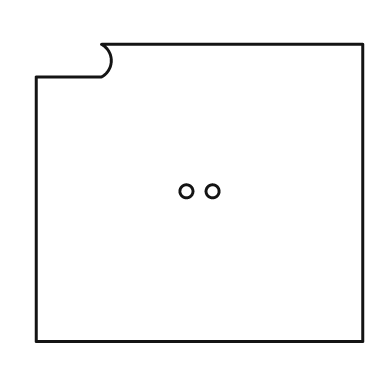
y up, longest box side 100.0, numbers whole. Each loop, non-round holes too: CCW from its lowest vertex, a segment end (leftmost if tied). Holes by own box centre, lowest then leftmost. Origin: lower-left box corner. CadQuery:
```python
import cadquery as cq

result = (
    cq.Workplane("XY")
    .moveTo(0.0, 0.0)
    .lineTo(100.0, 0.0)
    .lineTo(100.0, 91.0)
    .lineTo(20.0, 91.0)
    .threePointArc((23.0, 86.0), (20.0, 81.0))
    .lineTo(0.0, 81.0)
    .close()
    .moveTo(46.0, 46.0)
    .circle(2.0)
    .moveTo(54.0, 46.0)
    .circle(2.0)
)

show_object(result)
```